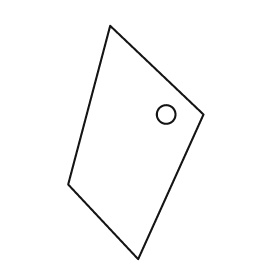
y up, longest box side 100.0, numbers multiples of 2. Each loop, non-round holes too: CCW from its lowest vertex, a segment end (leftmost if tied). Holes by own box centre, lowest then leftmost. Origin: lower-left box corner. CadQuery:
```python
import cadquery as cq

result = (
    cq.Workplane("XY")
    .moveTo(30.0, 0.0)
    .lineTo(58.0, 62.0)
    .lineTo(18.0, 100.0)
    .lineTo(0.0, 32.0)
    .close()
    .moveTo(42.0, 62.0)
    .circle(4.0)
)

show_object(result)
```